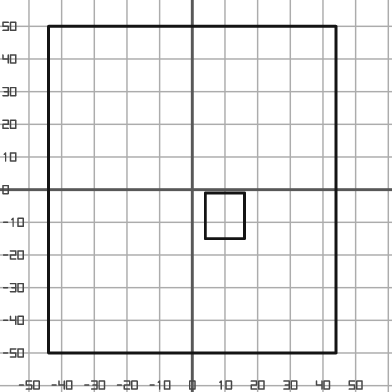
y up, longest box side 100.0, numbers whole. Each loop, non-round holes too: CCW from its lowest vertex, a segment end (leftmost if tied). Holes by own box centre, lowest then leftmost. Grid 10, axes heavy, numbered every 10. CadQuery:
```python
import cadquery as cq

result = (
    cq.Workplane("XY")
    .moveTo(-44.0, -50.0)
    .lineTo(44.0, -50.0)
    .lineTo(44.0, 50.0)
    .lineTo(-44.0, 50.0)
    .close()
    .moveTo(4.0, -15.0)
    .lineTo(16.0, -15.0)
    .lineTo(16.0, -1.0)
    .lineTo(4.0, -1.0)
    .close()
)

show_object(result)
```